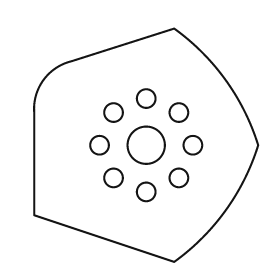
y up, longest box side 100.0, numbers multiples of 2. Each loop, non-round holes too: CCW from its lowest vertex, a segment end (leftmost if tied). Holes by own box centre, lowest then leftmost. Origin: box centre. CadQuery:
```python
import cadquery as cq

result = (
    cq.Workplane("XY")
    .moveTo(12.0, -50.0)
    .threePointArc((34.0, -28.0), (48.0, 0.0))
    .threePointArc((34.0, 28.0), (12.0, 50.0))
    .lineTo(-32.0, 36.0)
    .threePointArc((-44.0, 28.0), (-48.0, 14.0))
    .lineTo(-48.0, -30.0)
    .close()
    .moveTo(0.0, -20.0)
    .circle(4.0)
    .moveTo(-14.0, -14.0)
    .circle(4.0)
    .moveTo(14.0, -14.0)
    .circle(4.0)
    .moveTo(-20.0, 0.0)
    .circle(4.0)
    .moveTo(0.0, 0.0)
    .circle(8.0)
    .moveTo(20.0, 0.0)
    .circle(4.0)
    .moveTo(-14.0, 14.0)
    .circle(4.0)
    .moveTo(14.0, 14.0)
    .circle(4.0)
    .moveTo(0.0, 20.0)
    .circle(4.0)
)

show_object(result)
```